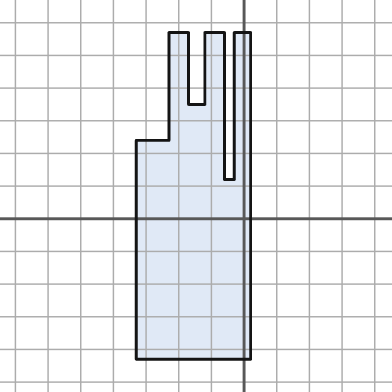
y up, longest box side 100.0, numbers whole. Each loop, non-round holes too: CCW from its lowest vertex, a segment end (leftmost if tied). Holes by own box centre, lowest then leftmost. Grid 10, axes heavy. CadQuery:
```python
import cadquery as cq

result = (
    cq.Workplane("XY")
    .moveTo(-33.0, -43.0)
    .lineTo(2.0, -43.0)
    .lineTo(2.0, 57.0)
    .lineTo(-3.0, 57.0)
    .lineTo(-3.0, 12.0)
    .lineTo(-6.0, 12.0)
    .lineTo(-6.0, 57.0)
    .lineTo(-12.0, 57.0)
    .lineTo(-12.0, 35.0)
    .lineTo(-17.0, 35.0)
    .lineTo(-17.0, 57.0)
    .lineTo(-23.0, 57.0)
    .lineTo(-23.0, 24.0)
    .lineTo(-33.0, 24.0)
    .close()
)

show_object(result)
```